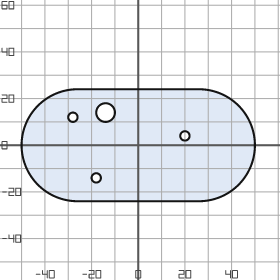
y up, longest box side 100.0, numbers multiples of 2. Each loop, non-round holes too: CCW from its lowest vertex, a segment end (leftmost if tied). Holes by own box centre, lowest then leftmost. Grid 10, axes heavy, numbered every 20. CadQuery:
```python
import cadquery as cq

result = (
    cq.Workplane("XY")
    .moveTo(-26.0, -24.0)
    .lineTo(26.0, -24.0)
    .threePointArc((50.0, 0.0), (26.0, 24.0))
    .lineTo(-26.0, 24.0)
    .threePointArc((-50.0, 0.0), (-26.0, -24.0))
    .close()
    .moveTo(-18.0, -14.0)
    .circle(2.0)
    .moveTo(20.0, 4.0)
    .circle(2.0)
    .moveTo(-28.0, 12.0)
    .circle(2.0)
    .moveTo(-14.0, 14.0)
    .circle(4.0)
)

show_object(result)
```